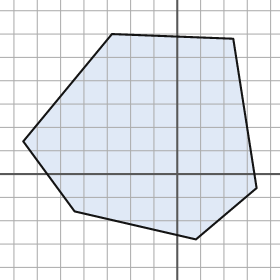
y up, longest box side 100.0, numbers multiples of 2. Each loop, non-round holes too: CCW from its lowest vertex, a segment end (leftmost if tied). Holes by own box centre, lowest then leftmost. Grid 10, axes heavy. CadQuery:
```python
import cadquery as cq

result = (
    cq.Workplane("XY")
    .moveTo(8.0, -28.0)
    .lineTo(34.0, -6.0)
    .lineTo(24.0, 58.0)
    .lineTo(-28.0, 60.0)
    .lineTo(-66.0, 14.0)
    .lineTo(-44.0, -16.0)
    .close()
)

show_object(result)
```